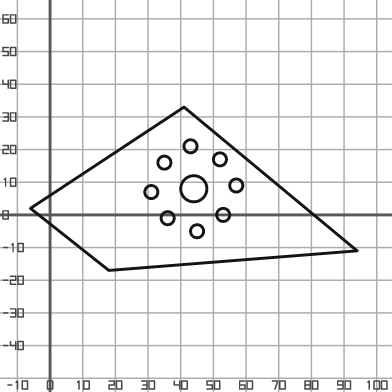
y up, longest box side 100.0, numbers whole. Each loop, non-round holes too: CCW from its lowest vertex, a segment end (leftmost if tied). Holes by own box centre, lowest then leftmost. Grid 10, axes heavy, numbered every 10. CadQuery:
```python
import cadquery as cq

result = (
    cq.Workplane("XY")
    .moveTo(18.0, -17.0)
    .lineTo(94.0, -11.0)
    .lineTo(41.0, 33.0)
    .lineTo(-6.0, 2.0)
    .close()
    .moveTo(45.0, -5.0)
    .circle(2.0)
    .moveTo(36.0, -1.0)
    .circle(2.0)
    .moveTo(53.0, 0.0)
    .circle(2.0)
    .moveTo(31.0, 7.0)
    .circle(2.0)
    .moveTo(44.0, 8.0)
    .circle(4.0)
    .moveTo(57.0, 9.0)
    .circle(2.0)
    .moveTo(35.0, 16.0)
    .circle(2.0)
    .moveTo(52.0, 17.0)
    .circle(2.0)
    .moveTo(43.0, 21.0)
    .circle(2.0)
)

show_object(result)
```